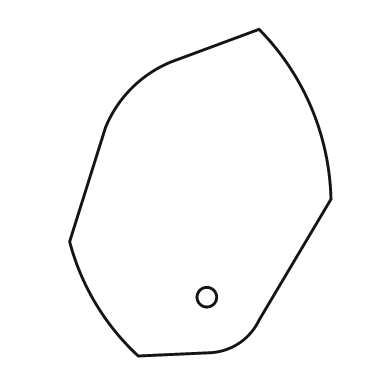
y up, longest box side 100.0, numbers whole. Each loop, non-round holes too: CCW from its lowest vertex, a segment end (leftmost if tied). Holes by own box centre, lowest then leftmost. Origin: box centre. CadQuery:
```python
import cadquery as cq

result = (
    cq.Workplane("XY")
    .moveTo(-19.0, -50.0)
    .lineTo(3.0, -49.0)
    .threePointArc((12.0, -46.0), (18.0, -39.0))
    .lineTo(40.0, -2.0)
    .threePointArc((34.0, 26.0), (18.0, 50.0))
    .lineTo(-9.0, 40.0)
    .threePointArc((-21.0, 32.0), (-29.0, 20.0))
    .lineTo(-40.0, -15.0)
    .threePointArc((-32.0, -34.0), (-19.0, -50.0))
    .close()
    .moveTo(2.0, -32.0)
    .circle(3.0)
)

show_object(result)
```